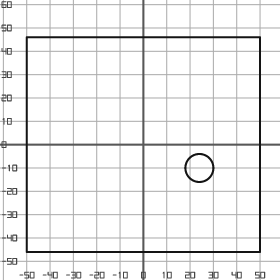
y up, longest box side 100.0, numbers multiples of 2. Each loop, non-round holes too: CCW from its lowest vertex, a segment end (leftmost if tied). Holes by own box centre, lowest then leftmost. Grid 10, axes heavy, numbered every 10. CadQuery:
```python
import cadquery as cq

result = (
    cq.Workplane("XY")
    .moveTo(-50.0, -46.0)
    .lineTo(50.0, -46.0)
    .lineTo(50.0, 46.0)
    .lineTo(-50.0, 46.0)
    .close()
    .moveTo(24.0, -10.0)
    .circle(6.0)
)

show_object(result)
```